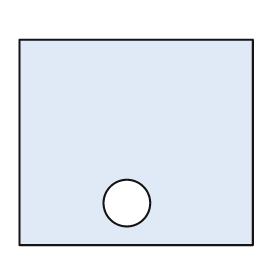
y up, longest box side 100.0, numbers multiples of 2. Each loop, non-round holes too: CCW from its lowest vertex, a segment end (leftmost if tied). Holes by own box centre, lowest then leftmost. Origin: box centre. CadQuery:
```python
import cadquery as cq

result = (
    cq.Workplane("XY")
    .moveTo(-50.0, -44.0)
    .lineTo(50.0, -44.0)
    .lineTo(50.0, 44.0)
    .lineTo(-50.0, 44.0)
    .close()
    .moveTo(-4.0, -26.0)
    .circle(10.0)
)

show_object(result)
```